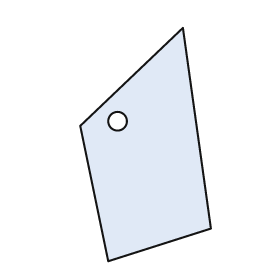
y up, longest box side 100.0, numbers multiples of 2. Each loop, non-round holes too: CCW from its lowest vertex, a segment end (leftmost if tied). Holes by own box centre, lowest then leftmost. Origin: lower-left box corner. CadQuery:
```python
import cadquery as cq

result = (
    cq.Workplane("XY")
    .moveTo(12.0, 0.0)
    .lineTo(56.0, 14.0)
    .lineTo(44.0, 100.0)
    .lineTo(0.0, 58.0)
    .close()
    .moveTo(16.0, 60.0)
    .circle(4.0)
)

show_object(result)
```